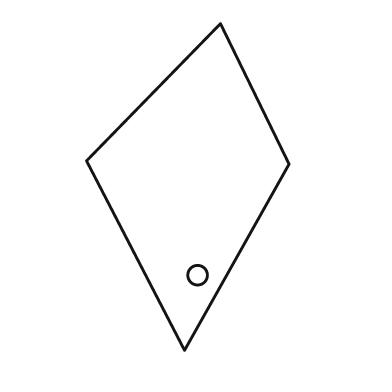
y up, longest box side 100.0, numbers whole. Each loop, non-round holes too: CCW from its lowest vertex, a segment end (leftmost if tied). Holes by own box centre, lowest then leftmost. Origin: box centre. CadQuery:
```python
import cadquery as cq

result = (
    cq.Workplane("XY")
    .moveTo(-1.0, -50.0)
    .lineTo(31.0, 7.0)
    .lineTo(10.0, 50.0)
    .lineTo(-31.0, 8.0)
    .close()
    .moveTo(3.0, -27.0)
    .circle(3.0)
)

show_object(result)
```